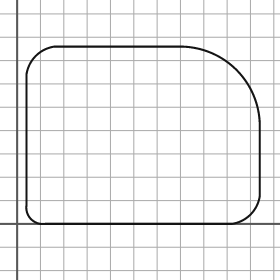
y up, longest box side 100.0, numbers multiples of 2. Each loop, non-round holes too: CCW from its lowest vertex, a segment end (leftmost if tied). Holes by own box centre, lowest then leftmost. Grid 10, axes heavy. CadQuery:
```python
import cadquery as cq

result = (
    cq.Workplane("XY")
    .moveTo(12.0, 0.0)
    .lineTo(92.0, 0.0)
    .threePointArc((100.0, 4.0), (104.0, 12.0))
    .lineTo(104.0, 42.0)
    .threePointArc((94.0, 66.0), (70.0, 76.0))
    .lineTo(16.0, 76.0)
    .threePointArc((8.0, 72.0), (4.0, 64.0))
    .lineTo(4.0, 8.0)
    .threePointArc((6.0, 2.0), (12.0, 0.0))
    .close()
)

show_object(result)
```